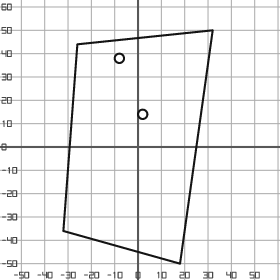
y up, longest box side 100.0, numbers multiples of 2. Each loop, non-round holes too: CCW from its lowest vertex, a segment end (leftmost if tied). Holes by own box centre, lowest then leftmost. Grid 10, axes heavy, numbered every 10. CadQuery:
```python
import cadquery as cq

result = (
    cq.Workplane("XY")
    .moveTo(18.0, -50.0)
    .lineTo(32.0, 50.0)
    .lineTo(-26.0, 44.0)
    .lineTo(-32.0, -36.0)
    .close()
    .moveTo(2.0, 14.0)
    .circle(2.0)
    .moveTo(-8.0, 38.0)
    .circle(2.0)
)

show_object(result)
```